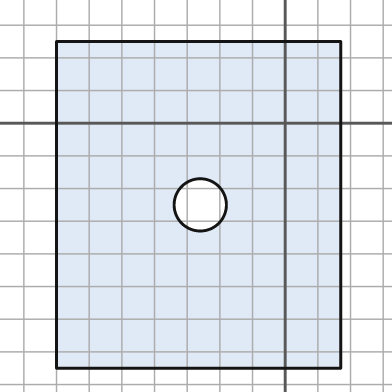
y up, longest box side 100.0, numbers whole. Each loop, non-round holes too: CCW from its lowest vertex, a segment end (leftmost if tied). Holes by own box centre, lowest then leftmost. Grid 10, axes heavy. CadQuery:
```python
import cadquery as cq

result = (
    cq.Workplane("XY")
    .moveTo(-70.0, -75.0)
    .lineTo(17.0, -75.0)
    .lineTo(17.0, 25.0)
    .lineTo(-70.0, 25.0)
    .close()
    .moveTo(-26.0, -25.0)
    .circle(8.0)
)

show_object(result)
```